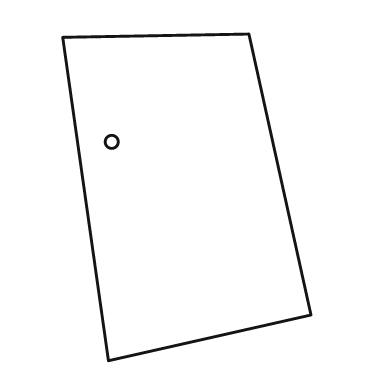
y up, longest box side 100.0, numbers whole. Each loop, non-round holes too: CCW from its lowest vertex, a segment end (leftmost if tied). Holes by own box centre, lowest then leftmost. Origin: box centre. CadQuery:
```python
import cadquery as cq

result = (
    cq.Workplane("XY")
    .moveTo(-24.0, -50.0)
    .lineTo(38.0, -36.0)
    .lineTo(19.0, 50.0)
    .lineTo(-38.0, 49.0)
    .close()
    .moveTo(-23.0, 17.0)
    .circle(2.0)
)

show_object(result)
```